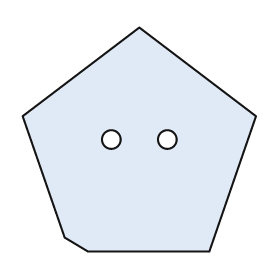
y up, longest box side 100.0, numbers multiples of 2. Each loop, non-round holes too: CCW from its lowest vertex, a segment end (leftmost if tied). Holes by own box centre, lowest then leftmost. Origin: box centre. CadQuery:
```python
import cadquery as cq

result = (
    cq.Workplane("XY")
    .moveTo(-22.0, -48.0)
    .lineTo(30.0, -48.0)
    .lineTo(50.0, 10.0)
    .lineTo(0.0, 48.0)
    .lineTo(-50.0, 10.0)
    .lineTo(-32.0, -42.0)
    .close()
    .moveTo(-12.0, 0.0)
    .circle(4.0)
    .moveTo(12.0, 0.0)
    .circle(4.0)
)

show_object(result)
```